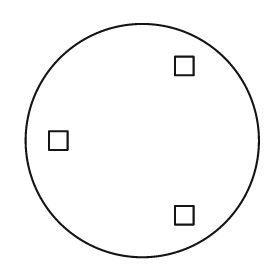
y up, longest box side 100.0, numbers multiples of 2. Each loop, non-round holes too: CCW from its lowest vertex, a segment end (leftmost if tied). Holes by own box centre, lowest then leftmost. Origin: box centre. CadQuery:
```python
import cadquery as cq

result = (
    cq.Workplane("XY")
    .moveTo(0.0, 0.0)
    .circle(50.0)
    .moveTo(14.0, -36.0)
    .lineTo(22.0, -36.0)
    .lineTo(22.0, -28.0)
    .lineTo(14.0, -28.0)
    .close()
    .moveTo(-40.0, -4.0)
    .lineTo(-32.0, -4.0)
    .lineTo(-32.0, 4.0)
    .lineTo(-40.0, 4.0)
    .close()
    .moveTo(14.0, 28.0)
    .lineTo(22.0, 28.0)
    .lineTo(22.0, 36.0)
    .lineTo(14.0, 36.0)
    .close()
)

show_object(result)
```